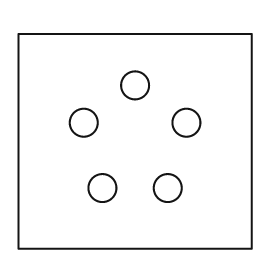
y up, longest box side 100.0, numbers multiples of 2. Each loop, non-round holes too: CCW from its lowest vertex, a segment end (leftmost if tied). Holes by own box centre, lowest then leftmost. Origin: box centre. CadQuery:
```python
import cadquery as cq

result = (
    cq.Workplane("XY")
    .moveTo(-50.0, -46.0)
    .lineTo(50.0, -46.0)
    .lineTo(50.0, 46.0)
    .lineTo(-50.0, 46.0)
    .close()
    .moveTo(-14.0, -20.0)
    .circle(6.0)
    .moveTo(14.0, -20.0)
    .circle(6.0)
    .moveTo(-22.0, 8.0)
    .circle(6.0)
    .moveTo(22.0, 8.0)
    .circle(6.0)
    .moveTo(0.0, 24.0)
    .circle(6.0)
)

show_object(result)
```